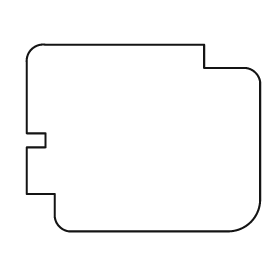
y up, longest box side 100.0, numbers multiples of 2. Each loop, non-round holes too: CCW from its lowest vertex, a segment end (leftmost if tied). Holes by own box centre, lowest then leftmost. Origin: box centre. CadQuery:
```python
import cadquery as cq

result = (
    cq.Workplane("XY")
    .moveTo(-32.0, -40.0)
    .lineTo(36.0, -40.0)
    .threePointArc((46.0, -36.0), (50.0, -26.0))
    .lineTo(50.0, 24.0)
    .threePointArc((48.0, 28.0), (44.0, 30.0))
    .lineTo(26.0, 30.0)
    .lineTo(26.0, 40.0)
    .lineTo(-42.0, 40.0)
    .threePointArc((-48.0, 38.0), (-50.0, 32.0))
    .lineTo(-50.0, 2.0)
    .lineTo(-42.0, 2.0)
    .lineTo(-42.0, -4.0)
    .lineTo(-50.0, -4.0)
    .lineTo(-50.0, -24.0)
    .lineTo(-38.0, -24.0)
    .lineTo(-38.0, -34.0)
    .threePointArc((-36.0, -38.0), (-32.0, -40.0))
    .close()
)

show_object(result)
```